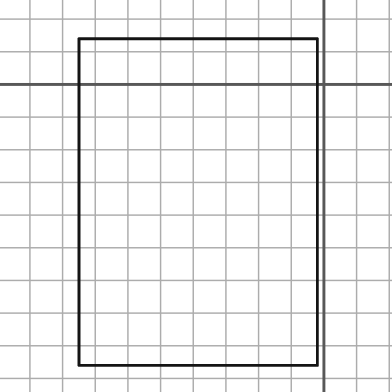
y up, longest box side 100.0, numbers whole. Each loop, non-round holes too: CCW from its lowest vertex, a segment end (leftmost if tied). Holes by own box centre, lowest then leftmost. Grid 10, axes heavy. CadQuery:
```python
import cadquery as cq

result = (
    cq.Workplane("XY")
    .moveTo(-75.0, -86.0)
    .lineTo(-2.0, -86.0)
    .lineTo(-2.0, 14.0)
    .lineTo(-75.0, 14.0)
    .close()
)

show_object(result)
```